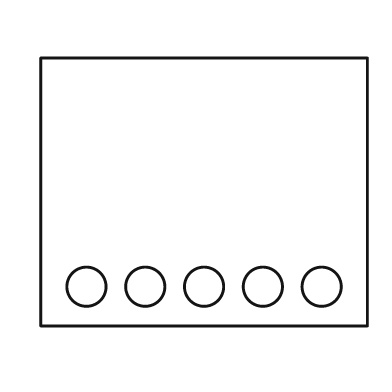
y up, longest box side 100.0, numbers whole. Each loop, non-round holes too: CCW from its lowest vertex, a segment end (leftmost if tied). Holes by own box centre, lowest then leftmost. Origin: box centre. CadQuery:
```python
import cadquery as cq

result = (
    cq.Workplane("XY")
    .moveTo(-50.0, -41.0)
    .lineTo(50.0, -41.0)
    .lineTo(50.0, 41.0)
    .lineTo(-50.0, 41.0)
    .close()
    .moveTo(-36.0, -29.0)
    .circle(6.0)
    .moveTo(-18.0, -29.0)
    .circle(6.0)
    .moveTo(0.0, -29.0)
    .circle(6.0)
    .moveTo(18.0, -29.0)
    .circle(6.0)
    .moveTo(36.0, -29.0)
    .circle(6.0)
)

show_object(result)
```